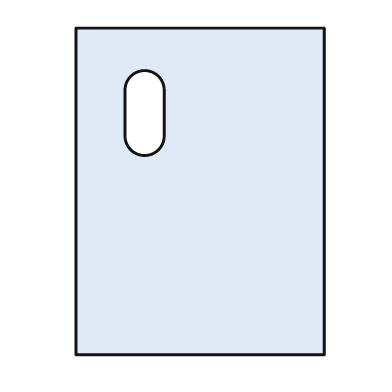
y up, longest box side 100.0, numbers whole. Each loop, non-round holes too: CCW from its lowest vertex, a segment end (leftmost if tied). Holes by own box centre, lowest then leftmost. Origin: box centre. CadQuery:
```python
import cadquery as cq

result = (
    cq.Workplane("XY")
    .moveTo(-38.0, -50.0)
    .lineTo(38.0, -50.0)
    .lineTo(38.0, 50.0)
    .lineTo(-38.0, 50.0)
    .close()
    .moveTo(-23.0, 17.0)
    .threePointArc((-17.0, 11.0), (-11.0, 17.0))
    .lineTo(-11.0, 31.0)
    .threePointArc((-17.0, 37.0), (-23.0, 31.0))
    .close()
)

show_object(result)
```